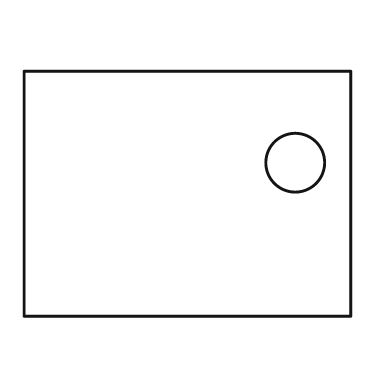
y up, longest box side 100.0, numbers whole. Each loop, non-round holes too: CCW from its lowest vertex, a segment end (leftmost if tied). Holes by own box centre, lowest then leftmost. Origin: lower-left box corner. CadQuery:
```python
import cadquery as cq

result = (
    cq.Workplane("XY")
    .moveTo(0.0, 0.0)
    .lineTo(100.0, 0.0)
    .lineTo(100.0, 75.0)
    .lineTo(0.0, 75.0)
    .close()
    .moveTo(83.0, 47.0)
    .circle(9.0)
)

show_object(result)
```